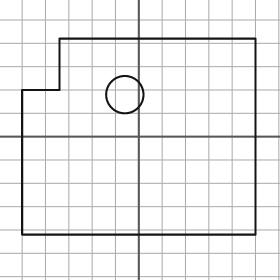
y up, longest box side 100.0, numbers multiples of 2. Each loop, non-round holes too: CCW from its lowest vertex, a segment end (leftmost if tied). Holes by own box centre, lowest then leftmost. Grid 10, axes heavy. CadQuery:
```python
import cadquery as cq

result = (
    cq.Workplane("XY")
    .moveTo(-50.0, -42.0)
    .lineTo(50.0, -42.0)
    .lineTo(50.0, 42.0)
    .lineTo(-34.0, 42.0)
    .lineTo(-34.0, 20.0)
    .lineTo(-50.0, 20.0)
    .close()
    .moveTo(-6.0, 18.0)
    .circle(8.0)
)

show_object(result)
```